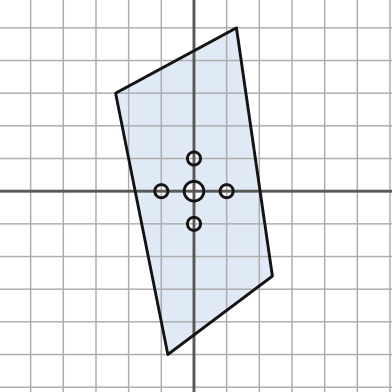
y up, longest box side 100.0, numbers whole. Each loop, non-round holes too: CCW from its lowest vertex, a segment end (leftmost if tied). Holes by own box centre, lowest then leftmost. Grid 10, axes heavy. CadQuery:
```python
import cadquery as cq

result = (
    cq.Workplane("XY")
    .moveTo(-8.0, -50.0)
    .lineTo(24.0, -26.0)
    .lineTo(13.0, 50.0)
    .lineTo(-24.0, 30.0)
    .close()
    .moveTo(0.0, -10.0)
    .circle(2.0)
    .moveTo(-10.0, 0.0)
    .circle(2.0)
    .moveTo(0.0, 0.0)
    .circle(3.0)
    .moveTo(10.0, 0.0)
    .circle(2.0)
    .moveTo(0.0, 10.0)
    .circle(2.0)
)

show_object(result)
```